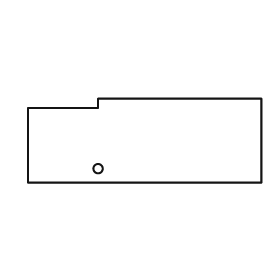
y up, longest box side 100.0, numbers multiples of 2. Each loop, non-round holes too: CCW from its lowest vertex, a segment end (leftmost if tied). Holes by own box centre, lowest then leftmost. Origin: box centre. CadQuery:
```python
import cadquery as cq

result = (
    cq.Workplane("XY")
    .moveTo(-50.0, -18.0)
    .lineTo(50.0, -18.0)
    .lineTo(50.0, 18.0)
    .lineTo(-20.0, 18.0)
    .lineTo(-20.0, 14.0)
    .lineTo(-50.0, 14.0)
    .close()
    .moveTo(-20.0, -12.0)
    .circle(2.0)
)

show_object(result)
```